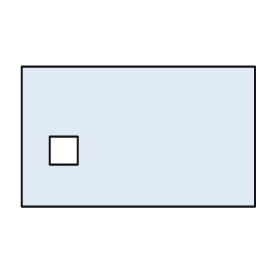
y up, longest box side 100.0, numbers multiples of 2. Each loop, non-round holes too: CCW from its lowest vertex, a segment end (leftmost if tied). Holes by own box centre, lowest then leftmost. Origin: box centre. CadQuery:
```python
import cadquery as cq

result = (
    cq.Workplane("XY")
    .moveTo(-50.0, -30.0)
    .lineTo(50.0, -30.0)
    .lineTo(50.0, 30.0)
    .lineTo(-50.0, 30.0)
    .close()
    .moveTo(-38.0, -12.0)
    .lineTo(-26.0, -12.0)
    .lineTo(-26.0, 0.0)
    .lineTo(-38.0, 0.0)
    .close()
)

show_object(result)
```